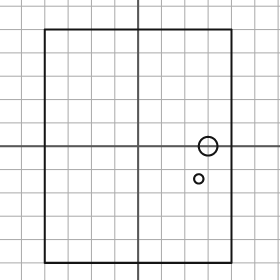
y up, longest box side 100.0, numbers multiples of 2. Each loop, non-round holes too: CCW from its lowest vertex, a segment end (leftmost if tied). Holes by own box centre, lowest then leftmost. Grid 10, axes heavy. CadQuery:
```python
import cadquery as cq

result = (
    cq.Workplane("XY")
    .moveTo(-40.0, -50.0)
    .lineTo(40.0, -50.0)
    .lineTo(40.0, 50.0)
    .lineTo(-40.0, 50.0)
    .close()
    .moveTo(26.0, -14.0)
    .circle(2.0)
    .moveTo(30.0, 0.0)
    .circle(4.0)
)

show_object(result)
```